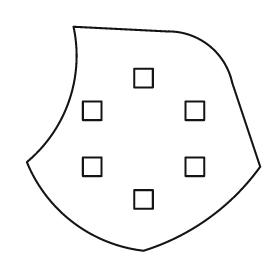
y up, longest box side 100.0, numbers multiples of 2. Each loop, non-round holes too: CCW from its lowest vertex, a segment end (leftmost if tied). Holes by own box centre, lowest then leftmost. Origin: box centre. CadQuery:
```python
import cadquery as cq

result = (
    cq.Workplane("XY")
    .moveTo(0.0, -48.0)
    .threePointArc((28.0, -34.0), (50.0, -12.0))
    .lineTo(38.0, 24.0)
    .threePointArc((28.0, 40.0), (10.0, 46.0))
    .lineTo(-30.0, 48.0)
    .threePointArc((-32.0, 16.0), (-50.0, -10.0))
    .threePointArc((-30.0, -36.0), (0.0, -48.0))
    .close()
    .moveTo(-4.0, -30.0)
    .lineTo(4.0, -30.0)
    .lineTo(4.0, -22.0)
    .lineTo(-4.0, -22.0)
    .close()
    .moveTo(-26.0, -16.0)
    .lineTo(-18.0, -16.0)
    .lineTo(-18.0, -8.0)
    .lineTo(-26.0, -8.0)
    .close()
    .moveTo(18.0, -16.0)
    .lineTo(26.0, -16.0)
    .lineTo(26.0, -8.0)
    .lineTo(18.0, -8.0)
    .close()
    .moveTo(-26.0, 8.0)
    .lineTo(-18.0, 8.0)
    .lineTo(-18.0, 16.0)
    .lineTo(-26.0, 16.0)
    .close()
    .moveTo(18.0, 8.0)
    .lineTo(26.0, 8.0)
    .lineTo(26.0, 16.0)
    .lineTo(18.0, 16.0)
    .close()
    .moveTo(-4.0, 22.0)
    .lineTo(4.0, 22.0)
    .lineTo(4.0, 30.0)
    .lineTo(-4.0, 30.0)
    .close()
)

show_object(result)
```